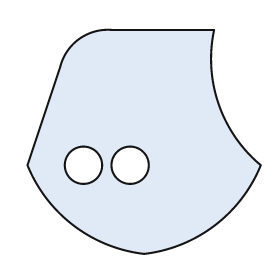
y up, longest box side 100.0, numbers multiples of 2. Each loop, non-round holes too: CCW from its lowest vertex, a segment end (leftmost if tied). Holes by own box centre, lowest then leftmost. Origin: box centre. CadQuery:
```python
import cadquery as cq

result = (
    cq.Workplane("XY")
    .moveTo(0.0, -48.0)
    .threePointArc((30.0, -36.0), (50.0, -10.0))
    .threePointArc((32.0, 16.0), (30.0, 48.0))
    .lineTo(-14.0, 48.0)
    .threePointArc((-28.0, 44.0), (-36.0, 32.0))
    .lineTo(-50.0, -10.0)
    .threePointArc((-30.0, -36.0), (0.0, -48.0))
    .close()
    .moveTo(-26.0, -10.0)
    .circle(8.0)
    .moveTo(-6.0, -10.0)
    .circle(8.0)
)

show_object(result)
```